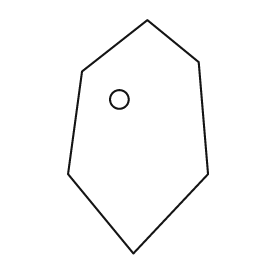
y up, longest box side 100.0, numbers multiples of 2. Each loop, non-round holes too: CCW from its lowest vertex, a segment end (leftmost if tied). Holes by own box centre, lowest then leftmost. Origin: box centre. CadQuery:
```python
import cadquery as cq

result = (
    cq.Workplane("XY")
    .moveTo(-2.0, -50.0)
    .lineTo(30.0, -16.0)
    .lineTo(26.0, 32.0)
    .lineTo(4.0, 50.0)
    .lineTo(-24.0, 28.0)
    .lineTo(-30.0, -16.0)
    .close()
    .moveTo(-8.0, 16.0)
    .circle(4.0)
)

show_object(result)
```